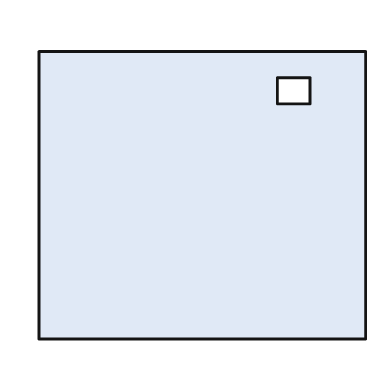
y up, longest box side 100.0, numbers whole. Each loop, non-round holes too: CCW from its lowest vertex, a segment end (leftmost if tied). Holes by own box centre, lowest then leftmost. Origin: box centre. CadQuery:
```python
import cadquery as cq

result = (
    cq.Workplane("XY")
    .moveTo(-50.0, -44.0)
    .lineTo(50.0, -44.0)
    .lineTo(50.0, 44.0)
    .lineTo(-50.0, 44.0)
    .close()
    .moveTo(23.0, 28.0)
    .lineTo(33.0, 28.0)
    .lineTo(33.0, 36.0)
    .lineTo(23.0, 36.0)
    .close()
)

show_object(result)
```